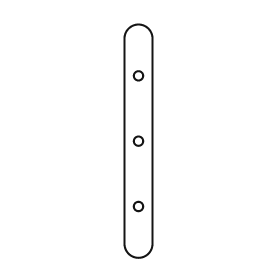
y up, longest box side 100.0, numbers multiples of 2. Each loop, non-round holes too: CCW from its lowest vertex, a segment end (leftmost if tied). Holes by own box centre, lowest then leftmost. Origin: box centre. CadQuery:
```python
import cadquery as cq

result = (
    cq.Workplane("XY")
    .moveTo(-6.0, -44.0)
    .threePointArc((0.0, -50.0), (6.0, -44.0))
    .lineTo(6.0, 44.0)
    .threePointArc((0.0, 50.0), (-6.0, 44.0))
    .close()
    .moveTo(0.0, -28.0)
    .circle(2.0)
    .moveTo(0.0, 0.0)
    .circle(2.0)
    .moveTo(0.0, 28.0)
    .circle(2.0)
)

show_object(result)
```